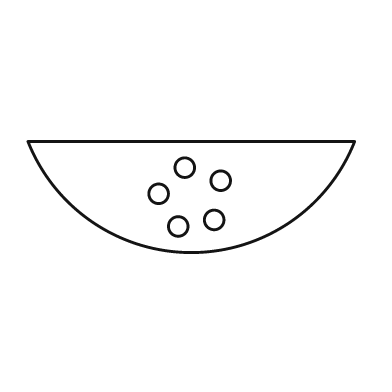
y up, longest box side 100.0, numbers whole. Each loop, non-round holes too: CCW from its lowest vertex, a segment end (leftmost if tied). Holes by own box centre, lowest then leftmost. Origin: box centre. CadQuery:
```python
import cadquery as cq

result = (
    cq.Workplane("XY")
    .moveTo(-50.0, 17.0)
    .threePointArc((0.0, -17.0), (50.0, 17.0))
    .close()
    .moveTo(-4.0, -9.0)
    .circle(3.0)
    .moveTo(7.0, -7.0)
    .circle(3.0)
    .moveTo(-10.0, 1.0)
    .circle(3.0)
    .moveTo(9.0, 5.0)
    .circle(3.0)
    .moveTo(-2.0, 9.0)
    .circle(3.0)
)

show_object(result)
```